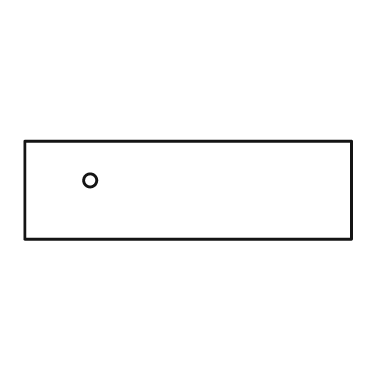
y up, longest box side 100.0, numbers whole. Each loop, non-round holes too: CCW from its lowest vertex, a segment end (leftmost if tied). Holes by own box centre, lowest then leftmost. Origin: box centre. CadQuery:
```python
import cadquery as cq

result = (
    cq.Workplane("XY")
    .moveTo(-50.0, -15.0)
    .lineTo(50.0, -15.0)
    .lineTo(50.0, 15.0)
    .lineTo(-50.0, 15.0)
    .close()
    .moveTo(-30.0, 3.0)
    .circle(2.0)
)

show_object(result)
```